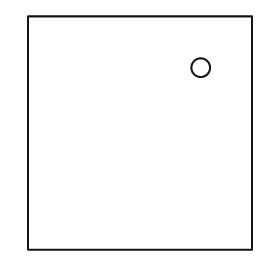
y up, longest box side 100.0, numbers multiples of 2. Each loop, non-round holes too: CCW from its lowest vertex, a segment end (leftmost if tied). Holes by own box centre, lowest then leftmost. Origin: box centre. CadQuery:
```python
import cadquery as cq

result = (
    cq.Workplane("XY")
    .moveTo(-48.0, -50.0)
    .lineTo(48.0, -50.0)
    .lineTo(48.0, 50.0)
    .lineTo(-48.0, 50.0)
    .close()
    .moveTo(26.0, 28.0)
    .circle(4.0)
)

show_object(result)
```